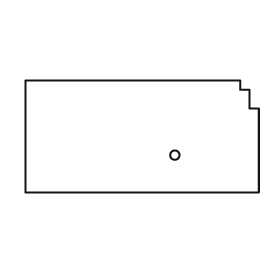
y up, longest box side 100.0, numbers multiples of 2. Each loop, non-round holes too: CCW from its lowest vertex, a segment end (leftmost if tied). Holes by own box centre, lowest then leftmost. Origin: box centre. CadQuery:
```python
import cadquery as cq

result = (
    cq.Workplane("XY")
    .moveTo(-50.0, -24.0)
    .lineTo(50.0, -24.0)
    .lineTo(50.0, 12.0)
    .lineTo(46.0, 12.0)
    .lineTo(46.0, 20.0)
    .lineTo(42.0, 20.0)
    .lineTo(42.0, 24.0)
    .lineTo(-50.0, 24.0)
    .close()
    .moveTo(14.0, -8.0)
    .circle(2.0)
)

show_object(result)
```